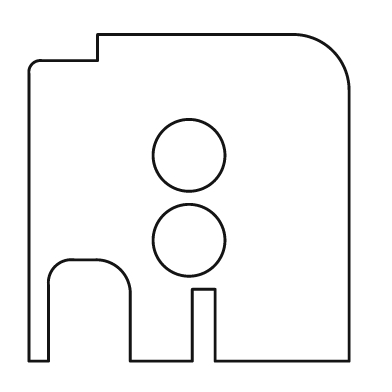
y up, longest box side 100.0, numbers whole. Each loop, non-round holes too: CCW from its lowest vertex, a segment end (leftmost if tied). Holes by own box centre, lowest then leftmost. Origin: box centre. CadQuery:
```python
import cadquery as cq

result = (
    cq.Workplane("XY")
    .moveTo(-49.0, -50.0)
    .lineTo(-43.0, -50.0)
    .lineTo(-43.0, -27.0)
    .threePointArc((-41.0, -21.0), (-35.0, -19.0))
    .lineTo(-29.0, -19.0)
    .threePointArc((-21.0, -22.0), (-18.0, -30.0))
    .lineTo(-18.0, -50.0)
    .lineTo(1.0, -50.0)
    .lineTo(1.0, -28.0)
    .lineTo(8.0, -28.0)
    .lineTo(8.0, -50.0)
    .lineTo(49.0, -50.0)
    .lineTo(49.0, 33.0)
    .threePointArc((44.0, 45.0), (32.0, 50.0))
    .lineTo(-28.0, 50.0)
    .lineTo(-28.0, 42.0)
    .lineTo(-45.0, 42.0)
    .threePointArc((-48.0, 41.0), (-49.0, 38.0))
    .close()
    .moveTo(0.0, -13.0)
    .circle(11.0)
    .moveTo(0.0, 13.0)
    .circle(11.0)
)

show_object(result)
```